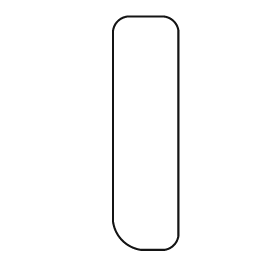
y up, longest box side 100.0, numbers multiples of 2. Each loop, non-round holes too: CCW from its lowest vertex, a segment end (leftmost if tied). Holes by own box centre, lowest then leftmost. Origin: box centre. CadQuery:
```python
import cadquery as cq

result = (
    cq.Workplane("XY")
    .moveTo(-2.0, -50.0)
    .lineTo(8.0, -50.0)
    .threePointArc((12.0, -48.0), (14.0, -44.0))
    .lineTo(14.0, 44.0)
    .threePointArc((12.0, 48.0), (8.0, 50.0))
    .lineTo(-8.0, 50.0)
    .threePointArc((-12.0, 48.0), (-14.0, 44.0))
    .lineTo(-14.0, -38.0)
    .threePointArc((-10.0, -46.0), (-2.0, -50.0))
    .close()
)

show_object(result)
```